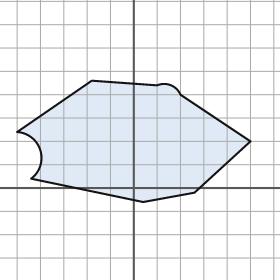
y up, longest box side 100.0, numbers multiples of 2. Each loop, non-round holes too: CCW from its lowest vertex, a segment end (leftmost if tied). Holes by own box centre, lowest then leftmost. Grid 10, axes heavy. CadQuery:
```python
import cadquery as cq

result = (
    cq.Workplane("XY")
    .moveTo(4.0, -6.0)
    .lineTo(26.0, -2.0)
    .lineTo(50.0, 20.0)
    .lineTo(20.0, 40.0)
    .threePointArc((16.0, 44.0), (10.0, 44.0))
    .lineTo(-18.0, 46.0)
    .lineTo(-50.0, 24.0)
    .threePointArc((-40.0, 16.0), (-44.0, 4.0))
    .close()
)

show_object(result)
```